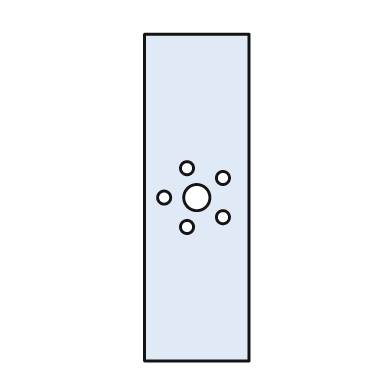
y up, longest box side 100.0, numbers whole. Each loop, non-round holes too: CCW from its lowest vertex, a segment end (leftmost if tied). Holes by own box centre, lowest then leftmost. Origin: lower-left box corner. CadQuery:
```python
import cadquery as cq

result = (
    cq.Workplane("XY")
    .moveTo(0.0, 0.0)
    .lineTo(32.0, 0.0)
    .lineTo(32.0, 100.0)
    .lineTo(0.0, 100.0)
    .close()
    .moveTo(13.0, 41.0)
    .circle(2.0)
    .moveTo(24.0, 44.0)
    .circle(2.0)
    .moveTo(6.0, 50.0)
    .circle(2.0)
    .moveTo(16.0, 50.0)
    .circle(4.0)
    .moveTo(24.0, 56.0)
    .circle(2.0)
    .moveTo(13.0, 59.0)
    .circle(2.0)
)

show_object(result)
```